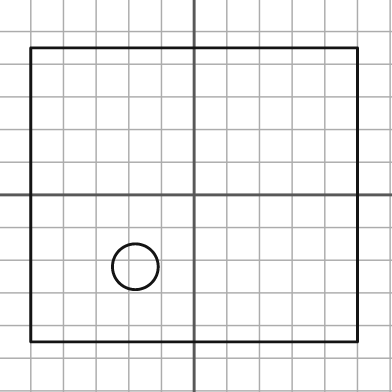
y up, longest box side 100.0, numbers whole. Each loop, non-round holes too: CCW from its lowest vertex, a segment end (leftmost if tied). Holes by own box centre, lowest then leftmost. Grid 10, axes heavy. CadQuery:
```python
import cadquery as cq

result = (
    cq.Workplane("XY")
    .moveTo(-50.0, -45.0)
    .lineTo(50.0, -45.0)
    .lineTo(50.0, 45.0)
    .lineTo(-50.0, 45.0)
    .close()
    .moveTo(-18.0, -22.0)
    .circle(7.0)
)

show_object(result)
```